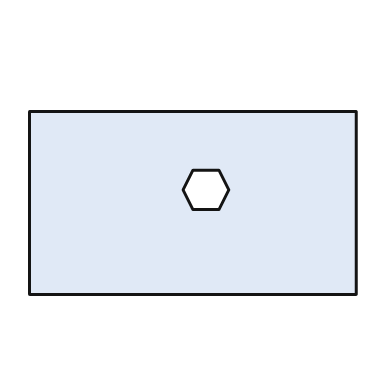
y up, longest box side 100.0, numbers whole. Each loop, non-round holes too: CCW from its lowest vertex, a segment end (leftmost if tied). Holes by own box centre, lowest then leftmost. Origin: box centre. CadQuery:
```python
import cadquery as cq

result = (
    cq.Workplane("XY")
    .moveTo(-50.0, -28.0)
    .lineTo(50.0, -28.0)
    .lineTo(50.0, 28.0)
    .lineTo(-50.0, 28.0)
    .close()
    .moveTo(0.0, -2.0)
    .lineTo(8.0, -2.0)
    .lineTo(11.0, 4.0)
    .lineTo(8.0, 10.0)
    .lineTo(0.0, 10.0)
    .lineTo(-3.0, 4.0)
    .close()
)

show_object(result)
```